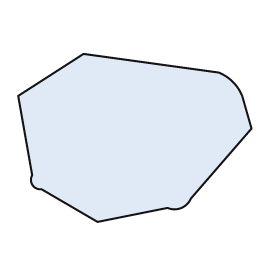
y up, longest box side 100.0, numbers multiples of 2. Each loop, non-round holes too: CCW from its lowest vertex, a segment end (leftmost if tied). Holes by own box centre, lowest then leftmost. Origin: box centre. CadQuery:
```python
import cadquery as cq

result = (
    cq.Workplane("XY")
    .moveTo(-16.0, -36.0)
    .lineTo(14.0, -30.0)
    .threePointArc((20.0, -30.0), (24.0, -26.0))
    .lineTo(50.0, 4.0)
    .lineTo(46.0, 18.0)
    .threePointArc((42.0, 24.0), (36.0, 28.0))
    .lineTo(-22.0, 36.0)
    .lineTo(-50.0, 18.0)
    .lineTo(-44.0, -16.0)
    .threePointArc((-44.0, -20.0), (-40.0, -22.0))
    .close()
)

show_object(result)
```